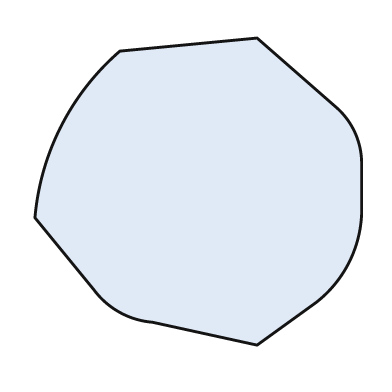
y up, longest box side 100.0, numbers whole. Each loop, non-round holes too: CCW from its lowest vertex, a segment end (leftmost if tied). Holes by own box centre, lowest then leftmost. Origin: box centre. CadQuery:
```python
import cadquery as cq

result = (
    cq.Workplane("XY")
    .moveTo(18.0, -47.0)
    .lineTo(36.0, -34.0)
    .threePointArc((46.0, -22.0), (50.0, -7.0))
    .lineTo(50.0, 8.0)
    .threePointArc((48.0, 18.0), (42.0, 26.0))
    .lineTo(18.0, 47.0)
    .lineTo(-24.0, 43.0)
    .threePointArc((-42.0, 20.0), (-50.0, -8.0))
    .lineTo(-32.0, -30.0)
    .threePointArc((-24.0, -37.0), (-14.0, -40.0))
    .close()
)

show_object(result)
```